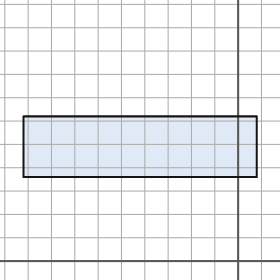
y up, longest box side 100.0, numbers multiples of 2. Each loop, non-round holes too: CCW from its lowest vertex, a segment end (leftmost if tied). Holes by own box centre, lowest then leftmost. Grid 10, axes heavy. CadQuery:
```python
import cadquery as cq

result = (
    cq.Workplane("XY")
    .moveTo(-92.0, 36.0)
    .lineTo(8.0, 36.0)
    .lineTo(8.0, 62.0)
    .lineTo(-92.0, 62.0)
    .close()
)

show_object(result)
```